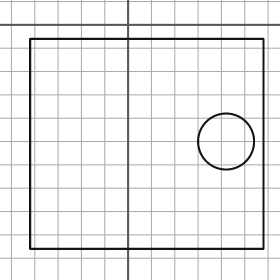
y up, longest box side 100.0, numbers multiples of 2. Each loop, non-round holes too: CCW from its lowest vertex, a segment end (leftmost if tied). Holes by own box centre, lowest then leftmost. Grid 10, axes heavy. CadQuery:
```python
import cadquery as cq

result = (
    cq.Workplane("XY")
    .moveTo(-42.0, -96.0)
    .lineTo(58.0, -96.0)
    .lineTo(58.0, -6.0)
    .lineTo(-42.0, -6.0)
    .close()
    .moveTo(42.0, -50.0)
    .circle(12.0)
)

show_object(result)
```